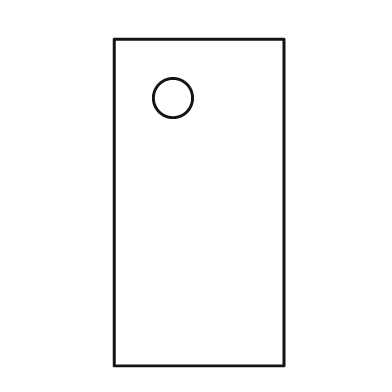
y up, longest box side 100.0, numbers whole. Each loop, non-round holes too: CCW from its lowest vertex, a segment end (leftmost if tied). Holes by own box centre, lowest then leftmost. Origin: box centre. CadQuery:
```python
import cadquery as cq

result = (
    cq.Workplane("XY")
    .moveTo(-26.0, -50.0)
    .lineTo(26.0, -50.0)
    .lineTo(26.0, 50.0)
    .lineTo(-26.0, 50.0)
    .close()
    .moveTo(-8.0, 32.0)
    .circle(6.0)
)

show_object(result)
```